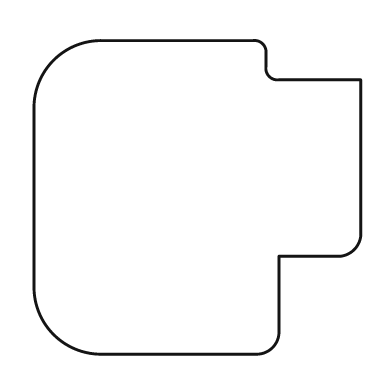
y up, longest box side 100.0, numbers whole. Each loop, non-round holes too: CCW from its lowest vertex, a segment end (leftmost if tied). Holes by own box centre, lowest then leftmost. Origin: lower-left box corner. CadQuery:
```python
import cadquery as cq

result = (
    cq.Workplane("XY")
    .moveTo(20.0, 0.0)
    .lineTo(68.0, 0.0)
    .threePointArc((73.0, 2.0), (75.0, 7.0))
    .lineTo(75.0, 30.0)
    .lineTo(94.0, 30.0)
    .threePointArc((98.0, 32.0), (100.0, 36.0))
    .lineTo(100.0, 84.0)
    .lineTo(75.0, 84.0)
    .threePointArc((72.0, 85.0), (71.0, 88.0))
    .lineTo(71.0, 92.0)
    .threePointArc((70.0, 95.0), (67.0, 96.0))
    .lineTo(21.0, 96.0)
    .threePointArc((6.0, 90.0), (0.0, 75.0))
    .lineTo(0.0, 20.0)
    .threePointArc((6.0, 6.0), (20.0, 0.0))
    .close()
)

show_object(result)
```